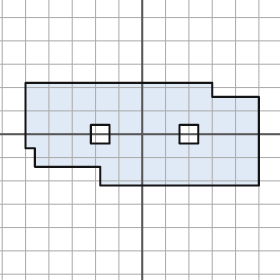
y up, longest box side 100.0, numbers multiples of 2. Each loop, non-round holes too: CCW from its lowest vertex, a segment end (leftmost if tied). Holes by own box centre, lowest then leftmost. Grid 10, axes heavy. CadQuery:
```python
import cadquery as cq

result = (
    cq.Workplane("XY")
    .moveTo(-18.0, -22.0)
    .lineTo(50.0, -22.0)
    .lineTo(50.0, 16.0)
    .lineTo(30.0, 16.0)
    .lineTo(30.0, 22.0)
    .lineTo(-50.0, 22.0)
    .lineTo(-50.0, -6.0)
    .lineTo(-46.0, -6.0)
    .lineTo(-46.0, -14.0)
    .lineTo(-18.0, -14.0)
    .close()
    .moveTo(-22.0, -4.0)
    .lineTo(-14.0, -4.0)
    .lineTo(-14.0, 4.0)
    .lineTo(-22.0, 4.0)
    .close()
    .moveTo(16.0, -4.0)
    .lineTo(24.0, -4.0)
    .lineTo(24.0, 4.0)
    .lineTo(16.0, 4.0)
    .close()
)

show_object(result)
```